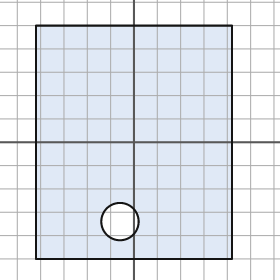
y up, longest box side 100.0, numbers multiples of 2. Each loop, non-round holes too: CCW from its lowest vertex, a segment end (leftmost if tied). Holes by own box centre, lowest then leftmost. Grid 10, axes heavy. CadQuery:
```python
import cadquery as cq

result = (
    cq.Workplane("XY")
    .moveTo(-42.0, -50.0)
    .lineTo(42.0, -50.0)
    .lineTo(42.0, 50.0)
    .lineTo(-42.0, 50.0)
    .close()
    .moveTo(-6.0, -34.0)
    .circle(8.0)
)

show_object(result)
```